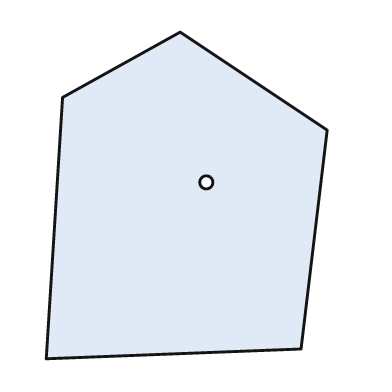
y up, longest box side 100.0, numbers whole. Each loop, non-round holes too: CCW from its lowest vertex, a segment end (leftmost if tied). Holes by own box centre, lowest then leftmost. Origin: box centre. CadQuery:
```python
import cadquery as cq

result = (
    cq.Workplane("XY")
    .moveTo(-43.0, -50.0)
    .lineTo(35.0, -47.0)
    .lineTo(43.0, 20.0)
    .lineTo(-2.0, 50.0)
    .lineTo(-38.0, 30.0)
    .close()
    .moveTo(6.0, 4.0)
    .circle(2.0)
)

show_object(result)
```